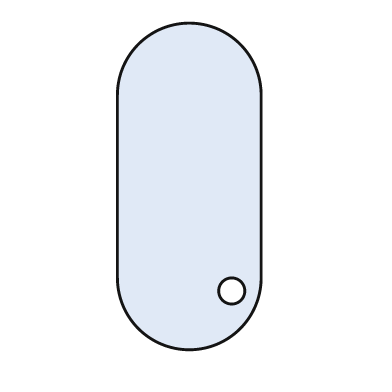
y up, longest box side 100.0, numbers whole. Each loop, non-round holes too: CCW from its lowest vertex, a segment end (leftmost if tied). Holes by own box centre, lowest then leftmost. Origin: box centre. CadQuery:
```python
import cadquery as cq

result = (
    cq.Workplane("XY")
    .moveTo(-22.0, -28.0)
    .threePointArc((0.0, -50.0), (22.0, -28.0))
    .lineTo(22.0, 28.0)
    .threePointArc((0.0, 50.0), (-22.0, 28.0))
    .close()
    .moveTo(13.0, -32.0)
    .circle(4.0)
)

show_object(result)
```